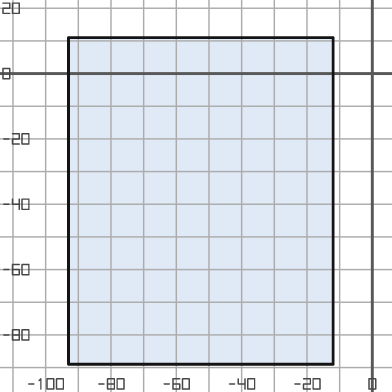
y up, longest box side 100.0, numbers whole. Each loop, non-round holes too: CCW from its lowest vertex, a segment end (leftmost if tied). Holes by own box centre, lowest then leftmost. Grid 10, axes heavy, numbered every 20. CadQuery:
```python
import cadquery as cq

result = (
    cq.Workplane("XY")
    .moveTo(-93.0, -89.0)
    .lineTo(-12.0, -89.0)
    .lineTo(-12.0, 11.0)
    .lineTo(-93.0, 11.0)
    .close()
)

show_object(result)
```